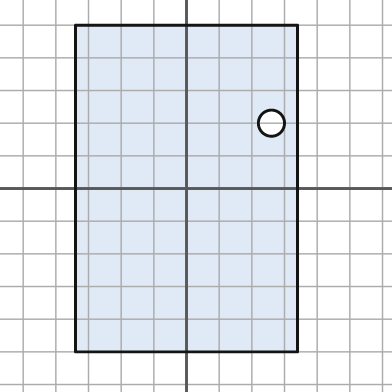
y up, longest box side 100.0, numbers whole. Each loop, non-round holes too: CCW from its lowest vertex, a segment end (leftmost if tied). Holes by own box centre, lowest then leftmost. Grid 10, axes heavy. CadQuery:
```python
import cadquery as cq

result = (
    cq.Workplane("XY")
    .moveTo(-34.0, -50.0)
    .lineTo(34.0, -50.0)
    .lineTo(34.0, 50.0)
    .lineTo(-34.0, 50.0)
    .close()
    .moveTo(26.0, 20.0)
    .circle(4.0)
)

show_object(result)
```